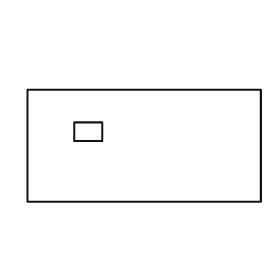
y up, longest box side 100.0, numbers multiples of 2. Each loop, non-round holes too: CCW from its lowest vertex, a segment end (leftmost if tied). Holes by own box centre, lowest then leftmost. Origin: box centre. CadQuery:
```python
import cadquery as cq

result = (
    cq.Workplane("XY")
    .moveTo(-50.0, -24.0)
    .lineTo(50.0, -24.0)
    .lineTo(50.0, 24.0)
    .lineTo(-50.0, 24.0)
    .close()
    .moveTo(-30.0, 2.0)
    .lineTo(-18.0, 2.0)
    .lineTo(-18.0, 10.0)
    .lineTo(-30.0, 10.0)
    .close()
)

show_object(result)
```